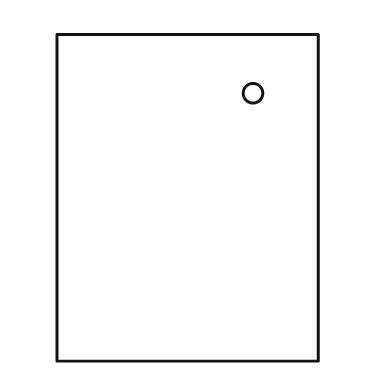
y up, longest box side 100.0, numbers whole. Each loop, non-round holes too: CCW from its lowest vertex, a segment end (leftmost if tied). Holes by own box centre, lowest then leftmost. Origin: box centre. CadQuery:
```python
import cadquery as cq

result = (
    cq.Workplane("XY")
    .moveTo(-40.0, -50.0)
    .lineTo(40.0, -50.0)
    .lineTo(40.0, 50.0)
    .lineTo(-40.0, 50.0)
    .close()
    .moveTo(20.0, 32.0)
    .circle(3.0)
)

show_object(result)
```